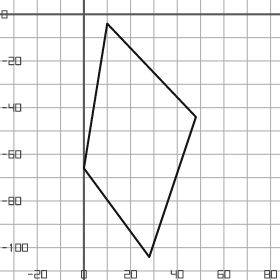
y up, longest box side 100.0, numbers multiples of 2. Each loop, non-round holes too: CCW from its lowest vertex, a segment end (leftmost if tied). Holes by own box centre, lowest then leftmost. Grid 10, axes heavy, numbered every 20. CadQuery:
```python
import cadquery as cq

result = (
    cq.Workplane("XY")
    .moveTo(28.0, -104.0)
    .lineTo(48.0, -44.0)
    .lineTo(10.0, -4.0)
    .lineTo(0.0, -66.0)
    .close()
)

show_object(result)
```